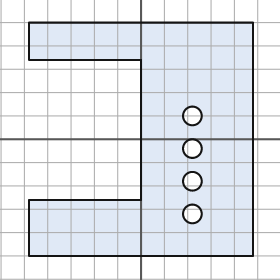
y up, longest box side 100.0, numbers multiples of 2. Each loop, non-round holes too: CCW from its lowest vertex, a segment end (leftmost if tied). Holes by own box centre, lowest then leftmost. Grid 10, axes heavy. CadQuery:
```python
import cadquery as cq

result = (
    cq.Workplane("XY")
    .moveTo(-48.0, -50.0)
    .lineTo(48.0, -50.0)
    .lineTo(48.0, 50.0)
    .lineTo(-48.0, 50.0)
    .lineTo(-48.0, 34.0)
    .lineTo(0.0, 34.0)
    .lineTo(0.0, -26.0)
    .lineTo(-48.0, -26.0)
    .close()
    .moveTo(22.0, -32.0)
    .circle(4.0)
    .moveTo(22.0, -18.0)
    .circle(4.0)
    .moveTo(22.0, -4.0)
    .circle(4.0)
    .moveTo(22.0, 10.0)
    .circle(4.0)
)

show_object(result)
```